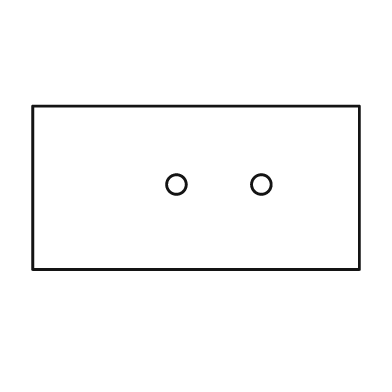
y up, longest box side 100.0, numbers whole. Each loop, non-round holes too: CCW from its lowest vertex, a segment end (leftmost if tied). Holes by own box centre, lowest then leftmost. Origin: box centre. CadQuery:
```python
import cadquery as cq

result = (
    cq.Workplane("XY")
    .moveTo(-50.0, -25.0)
    .lineTo(50.0, -25.0)
    .lineTo(50.0, 25.0)
    .lineTo(-50.0, 25.0)
    .close()
    .moveTo(-6.0, 1.0)
    .circle(3.0)
    .moveTo(20.0, 1.0)
    .circle(3.0)
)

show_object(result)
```